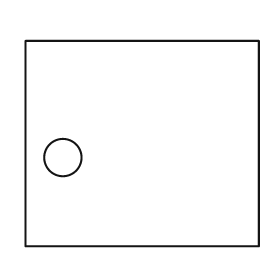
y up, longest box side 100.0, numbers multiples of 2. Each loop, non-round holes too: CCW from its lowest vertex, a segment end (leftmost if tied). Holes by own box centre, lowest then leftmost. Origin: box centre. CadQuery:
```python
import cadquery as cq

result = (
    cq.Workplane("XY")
    .moveTo(-50.0, -44.0)
    .lineTo(50.0, -44.0)
    .lineTo(50.0, 44.0)
    .lineTo(-50.0, 44.0)
    .close()
    .moveTo(-34.0, -6.0)
    .circle(8.0)
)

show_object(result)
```